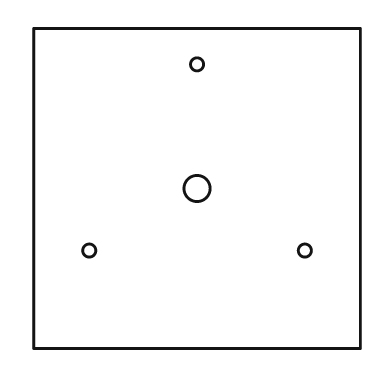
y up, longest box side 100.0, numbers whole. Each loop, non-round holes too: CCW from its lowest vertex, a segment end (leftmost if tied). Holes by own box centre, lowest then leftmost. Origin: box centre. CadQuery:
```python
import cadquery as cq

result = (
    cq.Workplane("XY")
    .moveTo(-50.0, -49.0)
    .lineTo(50.0, -49.0)
    .lineTo(50.0, 49.0)
    .lineTo(-50.0, 49.0)
    .close()
    .moveTo(-33.0, -19.0)
    .circle(2.0)
    .moveTo(33.0, -19.0)
    .circle(2.0)
    .moveTo(0.0, 0.0)
    .circle(4.0)
    .moveTo(0.0, 38.0)
    .circle(2.0)
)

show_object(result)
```